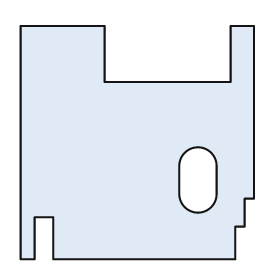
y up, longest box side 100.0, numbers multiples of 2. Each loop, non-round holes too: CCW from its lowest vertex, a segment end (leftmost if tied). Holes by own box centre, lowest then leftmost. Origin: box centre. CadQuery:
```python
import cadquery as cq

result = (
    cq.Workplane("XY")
    .moveTo(-50.0, -50.0)
    .lineTo(-44.0, -50.0)
    .lineTo(-44.0, -32.0)
    .lineTo(-36.0, -32.0)
    .lineTo(-36.0, -50.0)
    .lineTo(42.0, -50.0)
    .lineTo(42.0, -36.0)
    .lineTo(46.0, -36.0)
    .lineTo(46.0, -24.0)
    .lineTo(50.0, -24.0)
    .lineTo(50.0, 50.0)
    .lineTo(40.0, 50.0)
    .lineTo(40.0, 26.0)
    .lineTo(-14.0, 26.0)
    .lineTo(-14.0, 50.0)
    .lineTo(-50.0, 50.0)
    .close()
    .moveTo(18.0, -22.0)
    .threePointArc((26.0, -30.0), (34.0, -22.0))
    .lineTo(34.0, -10.0)
    .threePointArc((26.0, -2.0), (18.0, -10.0))
    .close()
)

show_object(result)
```